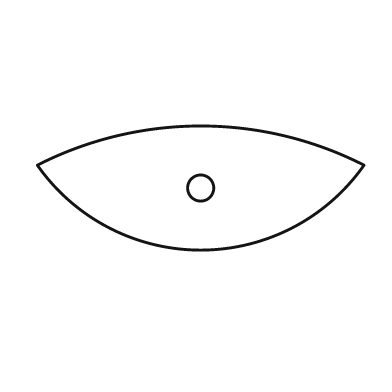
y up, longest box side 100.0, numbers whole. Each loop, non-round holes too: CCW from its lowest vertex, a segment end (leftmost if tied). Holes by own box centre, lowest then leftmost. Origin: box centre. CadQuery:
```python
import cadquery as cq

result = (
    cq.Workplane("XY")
    .moveTo(-50.0, 7.0)
    .threePointArc((0.0, -19.0), (50.0, 7.0))
    .threePointArc((0.0, 19.0), (-50.0, 7.0))
    .close()
    .moveTo(0.0, 0.0)
    .circle(4.0)
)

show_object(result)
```